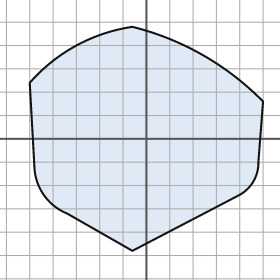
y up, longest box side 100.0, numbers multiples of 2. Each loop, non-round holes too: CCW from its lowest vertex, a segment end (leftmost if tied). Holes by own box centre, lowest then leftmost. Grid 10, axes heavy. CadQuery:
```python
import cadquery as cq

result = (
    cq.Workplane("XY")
    .moveTo(-6.0, -48.0)
    .lineTo(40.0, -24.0)
    .threePointArc((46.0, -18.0), (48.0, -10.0))
    .lineTo(50.0, 16.0)
    .threePointArc((24.0, 36.0), (-6.0, 48.0))
    .threePointArc((-30.0, 40.0), (-50.0, 24.0))
    .lineTo(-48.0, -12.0)
    .threePointArc((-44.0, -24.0), (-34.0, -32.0))
    .close()
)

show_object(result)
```